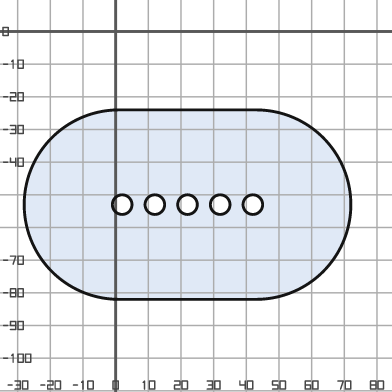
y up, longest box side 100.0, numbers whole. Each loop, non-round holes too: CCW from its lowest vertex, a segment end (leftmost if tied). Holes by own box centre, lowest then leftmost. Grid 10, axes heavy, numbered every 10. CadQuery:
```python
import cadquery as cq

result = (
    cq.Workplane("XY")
    .moveTo(1.0, -82.0)
    .lineTo(43.0, -82.0)
    .threePointArc((72.0, -53.0), (43.0, -24.0))
    .lineTo(1.0, -24.0)
    .threePointArc((-28.0, -53.0), (1.0, -82.0))
    .close()
    .moveTo(2.0, -53.0)
    .circle(3.0)
    .moveTo(12.0, -53.0)
    .circle(3.0)
    .moveTo(22.0, -53.0)
    .circle(3.0)
    .moveTo(32.0, -53.0)
    .circle(3.0)
    .moveTo(42.0, -53.0)
    .circle(3.0)
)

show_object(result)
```